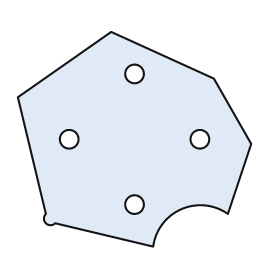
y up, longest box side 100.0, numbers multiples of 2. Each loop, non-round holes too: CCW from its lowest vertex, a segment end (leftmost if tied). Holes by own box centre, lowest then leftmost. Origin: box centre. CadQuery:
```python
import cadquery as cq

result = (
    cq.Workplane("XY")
    .moveTo(8.0, -46.0)
    .threePointArc((20.0, -30.0), (40.0, -32.0))
    .lineTo(50.0, -2.0)
    .lineTo(34.0, 26.0)
    .lineTo(-10.0, 46.0)
    .lineTo(-50.0, 18.0)
    .lineTo(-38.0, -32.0)
    .threePointArc((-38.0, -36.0), (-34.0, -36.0))
    .close()
    .moveTo(0.0, -28.0)
    .circle(4.0)
    .moveTo(-28.0, 0.0)
    .circle(4.0)
    .moveTo(28.0, 0.0)
    .circle(4.0)
    .moveTo(0.0, 28.0)
    .circle(4.0)
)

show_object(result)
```